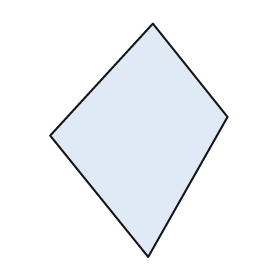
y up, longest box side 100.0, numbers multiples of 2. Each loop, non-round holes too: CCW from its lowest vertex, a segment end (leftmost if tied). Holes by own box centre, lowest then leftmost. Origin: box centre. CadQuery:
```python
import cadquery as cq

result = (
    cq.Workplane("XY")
    .moveTo(4.0, -50.0)
    .lineTo(38.0, 10.0)
    .lineTo(6.0, 50.0)
    .lineTo(-38.0, 2.0)
    .close()
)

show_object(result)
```